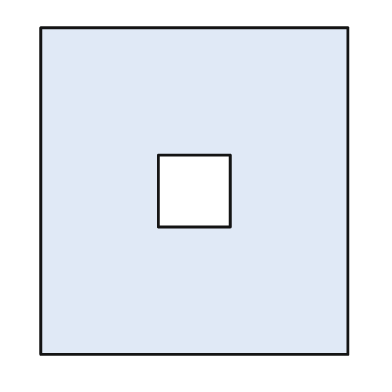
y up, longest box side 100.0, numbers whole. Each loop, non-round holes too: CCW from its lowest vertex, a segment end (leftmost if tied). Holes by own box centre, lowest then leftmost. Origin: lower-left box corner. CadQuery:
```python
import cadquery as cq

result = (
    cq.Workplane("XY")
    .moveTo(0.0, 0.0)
    .lineTo(94.0, 0.0)
    .lineTo(94.0, 100.0)
    .lineTo(0.0, 100.0)
    .close()
    .moveTo(36.0, 39.0)
    .lineTo(58.0, 39.0)
    .lineTo(58.0, 61.0)
    .lineTo(36.0, 61.0)
    .close()
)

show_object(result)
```